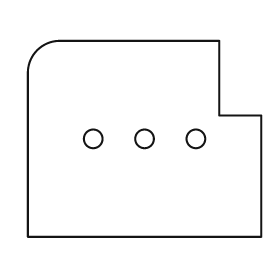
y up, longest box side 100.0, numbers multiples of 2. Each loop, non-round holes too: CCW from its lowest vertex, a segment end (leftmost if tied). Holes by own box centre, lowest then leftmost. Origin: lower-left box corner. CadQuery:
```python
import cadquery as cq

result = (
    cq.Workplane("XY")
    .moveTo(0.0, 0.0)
    .lineTo(100.0, 0.0)
    .lineTo(100.0, 52.0)
    .lineTo(82.0, 52.0)
    .lineTo(82.0, 84.0)
    .lineTo(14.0, 84.0)
    .threePointArc((4.0, 80.0), (0.0, 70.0))
    .close()
    .moveTo(28.0, 42.0)
    .circle(4.0)
    .moveTo(50.0, 42.0)
    .circle(4.0)
    .moveTo(72.0, 42.0)
    .circle(4.0)
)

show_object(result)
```